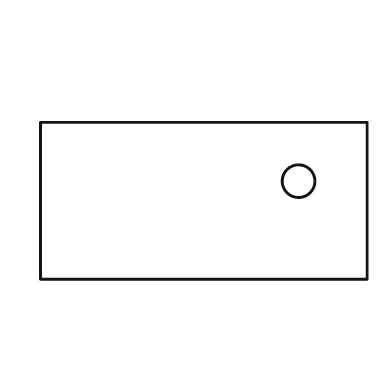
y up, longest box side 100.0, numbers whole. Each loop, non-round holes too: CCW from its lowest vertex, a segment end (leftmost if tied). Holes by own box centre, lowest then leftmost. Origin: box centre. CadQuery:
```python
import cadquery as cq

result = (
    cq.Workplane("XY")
    .moveTo(-50.0, -24.0)
    .lineTo(50.0, -24.0)
    .lineTo(50.0, 24.0)
    .lineTo(-50.0, 24.0)
    .close()
    .moveTo(29.0, 6.0)
    .circle(5.0)
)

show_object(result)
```